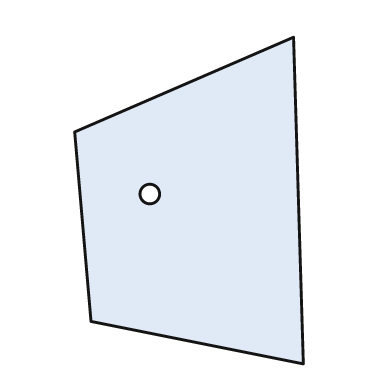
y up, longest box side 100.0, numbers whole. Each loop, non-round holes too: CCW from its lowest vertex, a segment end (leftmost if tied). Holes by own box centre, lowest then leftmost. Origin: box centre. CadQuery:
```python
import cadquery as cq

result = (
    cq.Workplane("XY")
    .moveTo(35.0, -50.0)
    .lineTo(32.0, 50.0)
    .lineTo(-35.0, 21.0)
    .lineTo(-30.0, -37.0)
    .close()
    .moveTo(-12.0, 2.0)
    .circle(3.0)
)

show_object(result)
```